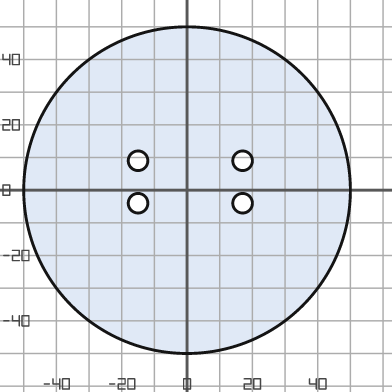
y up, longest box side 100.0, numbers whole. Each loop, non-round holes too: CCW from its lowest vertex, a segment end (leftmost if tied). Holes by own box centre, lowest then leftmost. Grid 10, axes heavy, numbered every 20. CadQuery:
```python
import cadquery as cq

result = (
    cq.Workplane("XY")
    .moveTo(0.0, 0.0)
    .circle(50.0)
    .moveTo(-15.0, -4.0)
    .circle(3.0)
    .moveTo(17.0, -4.0)
    .circle(3.0)
    .moveTo(-15.0, 9.0)
    .circle(3.0)
    .moveTo(17.0, 9.0)
    .circle(3.0)
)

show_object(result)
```